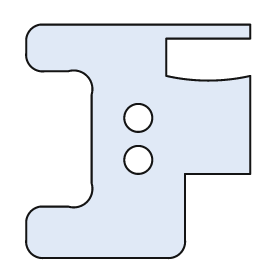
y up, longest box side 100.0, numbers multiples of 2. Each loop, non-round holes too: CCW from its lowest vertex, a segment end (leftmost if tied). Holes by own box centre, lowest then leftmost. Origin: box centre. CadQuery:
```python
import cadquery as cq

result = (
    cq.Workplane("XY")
    .moveTo(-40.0, -50.0)
    .lineTo(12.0, -50.0)
    .threePointArc((18.0, -48.0), (20.0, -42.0))
    .lineTo(20.0, -14.0)
    .lineTo(48.0, -14.0)
    .lineTo(48.0, 28.0)
    .threePointArc((30.0, 26.0), (12.0, 28.0))
    .lineTo(12.0, 44.0)
    .lineTo(48.0, 44.0)
    .lineTo(48.0, 50.0)
    .lineTo(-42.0, 50.0)
    .threePointArc((-46.0, 48.0), (-48.0, 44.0))
    .lineTo(-48.0, 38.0)
    .threePointArc((-46.0, 32.0), (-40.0, 30.0))
    .lineTo(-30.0, 30.0)
    .threePointArc((-22.0, 28.0), (-20.0, 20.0))
    .lineTo(-20.0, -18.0)
    .threePointArc((-22.0, -26.0), (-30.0, -28.0))
    .lineTo(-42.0, -28.0)
    .threePointArc((-46.0, -30.0), (-48.0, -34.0))
    .lineTo(-48.0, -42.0)
    .threePointArc((-46.0, -48.0), (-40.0, -50.0))
    .close()
    .moveTo(0.0, -8.0)
    .circle(6.0)
    .moveTo(0.0, 10.0)
    .circle(6.0)
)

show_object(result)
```